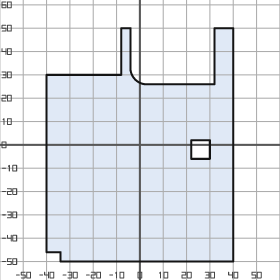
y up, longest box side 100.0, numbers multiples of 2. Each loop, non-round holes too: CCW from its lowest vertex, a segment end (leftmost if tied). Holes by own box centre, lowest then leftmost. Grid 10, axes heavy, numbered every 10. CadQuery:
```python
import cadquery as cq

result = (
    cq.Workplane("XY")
    .moveTo(-34.0, -50.0)
    .lineTo(40.0, -50.0)
    .lineTo(40.0, 50.0)
    .lineTo(32.0, 50.0)
    .lineTo(32.0, 26.0)
    .lineTo(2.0, 26.0)
    .threePointArc((-2.0, 28.0), (-4.0, 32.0))
    .lineTo(-4.0, 50.0)
    .lineTo(-8.0, 50.0)
    .lineTo(-8.0, 30.0)
    .lineTo(-40.0, 30.0)
    .lineTo(-40.0, -46.0)
    .lineTo(-34.0, -46.0)
    .close()
    .moveTo(22.0, -6.0)
    .lineTo(30.0, -6.0)
    .lineTo(30.0, 2.0)
    .lineTo(22.0, 2.0)
    .close()
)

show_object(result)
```